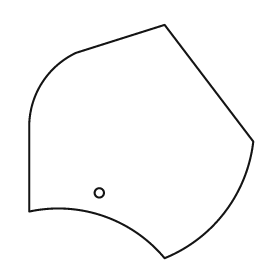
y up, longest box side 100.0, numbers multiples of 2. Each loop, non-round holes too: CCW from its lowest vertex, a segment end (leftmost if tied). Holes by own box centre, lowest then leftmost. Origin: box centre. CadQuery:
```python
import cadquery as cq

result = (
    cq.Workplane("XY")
    .moveTo(10.0, -50.0)
    .threePointArc((36.0, -30.0), (48.0, 0.0))
    .lineTo(10.0, 50.0)
    .lineTo(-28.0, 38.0)
    .threePointArc((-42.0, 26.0), (-48.0, 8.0))
    .lineTo(-48.0, -30.0)
    .threePointArc((-16.0, -32.0), (10.0, -50.0))
    .close()
    .moveTo(-18.0, -22.0)
    .circle(2.0)
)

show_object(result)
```